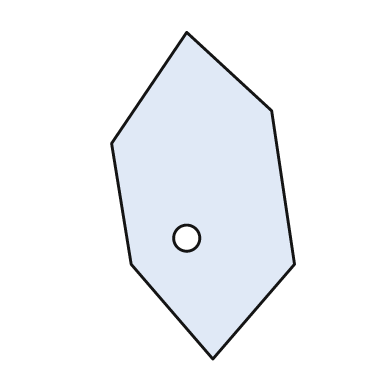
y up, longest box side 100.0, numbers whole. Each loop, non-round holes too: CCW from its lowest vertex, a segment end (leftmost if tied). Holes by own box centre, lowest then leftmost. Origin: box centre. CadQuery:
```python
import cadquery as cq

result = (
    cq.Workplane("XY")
    .moveTo(3.0, -50.0)
    .lineTo(28.0, -21.0)
    .lineTo(21.0, 26.0)
    .lineTo(-5.0, 50.0)
    .lineTo(-28.0, 16.0)
    .lineTo(-22.0, -21.0)
    .close()
    .moveTo(-5.0, -13.0)
    .circle(4.0)
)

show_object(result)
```